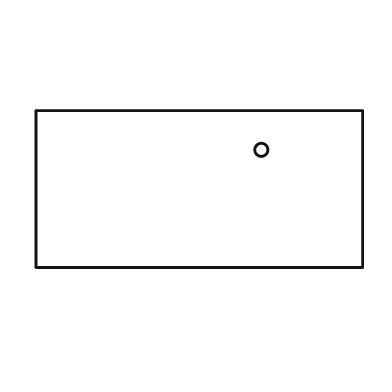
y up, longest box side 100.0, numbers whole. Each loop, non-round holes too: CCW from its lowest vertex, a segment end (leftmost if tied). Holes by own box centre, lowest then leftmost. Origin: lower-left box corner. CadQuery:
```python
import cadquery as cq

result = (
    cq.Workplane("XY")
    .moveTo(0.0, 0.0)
    .lineTo(100.0, 0.0)
    .lineTo(100.0, 48.0)
    .lineTo(0.0, 48.0)
    .close()
    .moveTo(69.0, 36.0)
    .circle(2.0)
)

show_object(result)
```